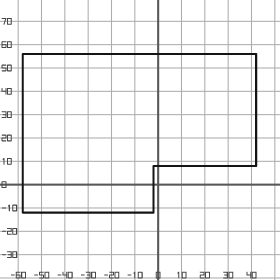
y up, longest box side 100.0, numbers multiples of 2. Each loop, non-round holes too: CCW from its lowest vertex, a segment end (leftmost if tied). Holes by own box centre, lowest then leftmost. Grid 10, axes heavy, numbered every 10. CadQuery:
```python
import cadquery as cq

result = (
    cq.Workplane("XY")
    .moveTo(-58.0, -12.0)
    .lineTo(-2.0, -12.0)
    .lineTo(-2.0, 8.0)
    .lineTo(42.0, 8.0)
    .lineTo(42.0, 56.0)
    .lineTo(-58.0, 56.0)
    .close()
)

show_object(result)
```